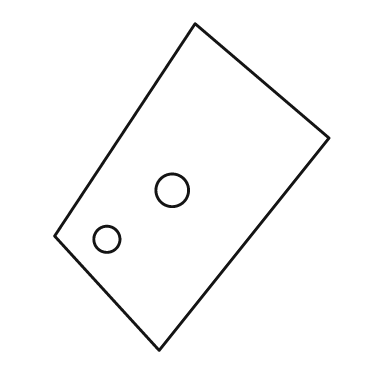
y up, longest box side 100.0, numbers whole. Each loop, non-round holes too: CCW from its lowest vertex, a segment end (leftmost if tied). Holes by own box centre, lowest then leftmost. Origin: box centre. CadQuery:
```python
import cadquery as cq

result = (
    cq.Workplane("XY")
    .moveTo(-10.0, -50.0)
    .lineTo(42.0, 15.0)
    .lineTo(1.0, 50.0)
    .lineTo(-42.0, -15.0)
    .close()
    .moveTo(-26.0, -16.0)
    .circle(4.0)
    .moveTo(-6.0, -1.0)
    .circle(5.0)
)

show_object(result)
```